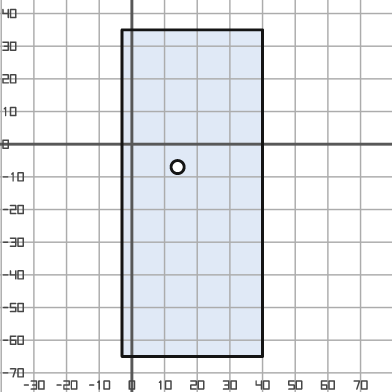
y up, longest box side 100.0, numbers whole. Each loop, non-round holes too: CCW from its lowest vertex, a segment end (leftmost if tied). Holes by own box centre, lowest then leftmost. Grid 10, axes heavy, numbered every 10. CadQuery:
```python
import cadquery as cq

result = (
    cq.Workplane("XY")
    .moveTo(-3.0, -65.0)
    .lineTo(40.0, -65.0)
    .lineTo(40.0, 35.0)
    .lineTo(-3.0, 35.0)
    .close()
    .moveTo(14.0, -7.0)
    .circle(2.0)
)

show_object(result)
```